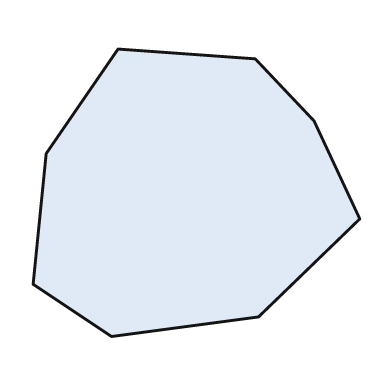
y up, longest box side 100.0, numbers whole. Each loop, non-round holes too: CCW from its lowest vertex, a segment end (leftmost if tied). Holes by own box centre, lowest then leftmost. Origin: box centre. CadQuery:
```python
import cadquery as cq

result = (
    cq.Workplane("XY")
    .moveTo(-26.0, -44.0)
    .lineTo(19.0, -38.0)
    .lineTo(50.0, -8.0)
    .lineTo(36.0, 22.0)
    .lineTo(18.0, 41.0)
    .lineTo(-24.0, 44.0)
    .lineTo(-46.0, 12.0)
    .lineTo(-50.0, -28.0)
    .close()
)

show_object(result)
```